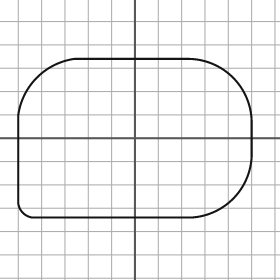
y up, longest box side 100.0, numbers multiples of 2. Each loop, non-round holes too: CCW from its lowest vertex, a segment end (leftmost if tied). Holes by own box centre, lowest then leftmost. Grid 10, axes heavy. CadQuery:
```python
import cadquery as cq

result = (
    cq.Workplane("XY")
    .moveTo(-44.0, -34.0)
    .lineTo(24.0, -34.0)
    .threePointArc((42.0, -26.0), (50.0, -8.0))
    .lineTo(50.0, 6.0)
    .threePointArc((42.0, 26.0), (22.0, 34.0))
    .lineTo(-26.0, 34.0)
    .threePointArc((-42.0, 26.0), (-50.0, 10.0))
    .lineTo(-50.0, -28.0)
    .threePointArc((-48.0, -32.0), (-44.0, -34.0))
    .close()
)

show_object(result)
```